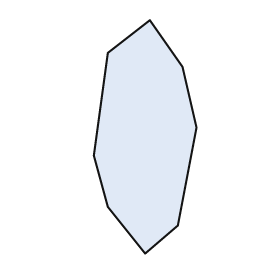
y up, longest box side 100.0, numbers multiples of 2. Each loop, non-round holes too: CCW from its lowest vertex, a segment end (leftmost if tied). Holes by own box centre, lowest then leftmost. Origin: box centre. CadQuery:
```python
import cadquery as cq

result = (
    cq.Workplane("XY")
    .moveTo(0.0, -50.0)
    .lineTo(14.0, -38.0)
    .lineTo(22.0, 4.0)
    .lineTo(16.0, 30.0)
    .lineTo(2.0, 50.0)
    .lineTo(-16.0, 36.0)
    .lineTo(-22.0, -8.0)
    .lineTo(-16.0, -30.0)
    .close()
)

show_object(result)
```